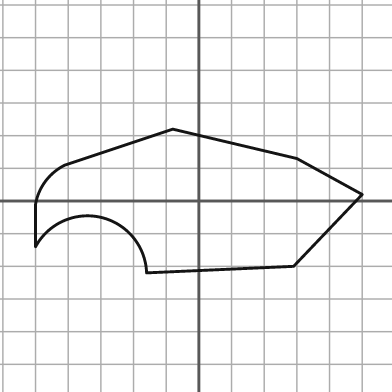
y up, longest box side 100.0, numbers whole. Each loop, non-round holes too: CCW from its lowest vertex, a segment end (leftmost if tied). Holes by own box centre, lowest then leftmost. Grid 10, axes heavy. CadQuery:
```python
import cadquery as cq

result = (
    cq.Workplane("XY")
    .moveTo(-16.0, -22.0)
    .lineTo(29.0, -20.0)
    .lineTo(50.0, 2.0)
    .lineTo(30.0, 13.0)
    .lineTo(-8.0, 22.0)
    .lineTo(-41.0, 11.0)
    .threePointArc((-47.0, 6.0), (-50.0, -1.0))
    .lineTo(-50.0, -14.0)
    .threePointArc((-30.0, -5.0), (-16.0, -22.0))
    .close()
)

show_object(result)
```